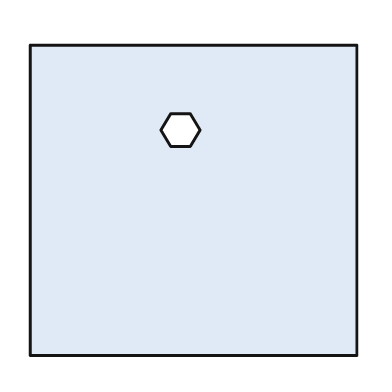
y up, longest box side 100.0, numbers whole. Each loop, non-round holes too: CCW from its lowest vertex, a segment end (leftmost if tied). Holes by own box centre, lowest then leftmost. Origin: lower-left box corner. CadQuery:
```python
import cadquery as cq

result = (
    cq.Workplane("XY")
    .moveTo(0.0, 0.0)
    .lineTo(100.0, 0.0)
    .lineTo(100.0, 95.0)
    .lineTo(0.0, 95.0)
    .close()
    .moveTo(43.0, 64.0)
    .lineTo(49.0, 64.0)
    .lineTo(52.0, 69.0)
    .lineTo(49.0, 74.0)
    .lineTo(43.0, 74.0)
    .lineTo(40.0, 69.0)
    .close()
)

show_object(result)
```